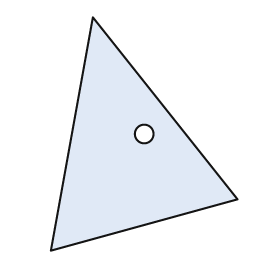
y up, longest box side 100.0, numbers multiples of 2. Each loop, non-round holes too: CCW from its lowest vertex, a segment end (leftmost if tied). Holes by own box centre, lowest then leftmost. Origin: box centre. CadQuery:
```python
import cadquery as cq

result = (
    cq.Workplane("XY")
    .moveTo(-40.0, -50.0)
    .lineTo(40.0, -28.0)
    .lineTo(-22.0, 50.0)
    .close()
    .moveTo(0.0, 0.0)
    .circle(4.0)
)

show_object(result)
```